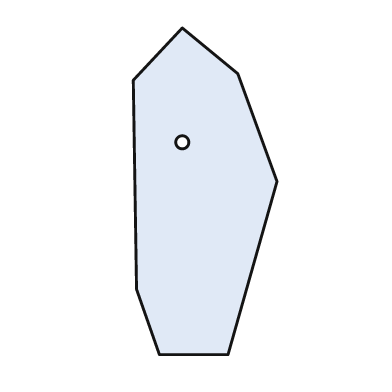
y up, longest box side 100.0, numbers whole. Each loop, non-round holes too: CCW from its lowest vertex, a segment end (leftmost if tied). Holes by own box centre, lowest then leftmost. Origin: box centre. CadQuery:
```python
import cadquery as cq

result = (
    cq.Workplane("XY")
    .moveTo(-14.0, -50.0)
    .lineTo(7.0, -50.0)
    .lineTo(22.0, 3.0)
    .lineTo(10.0, 36.0)
    .lineTo(-7.0, 50.0)
    .lineTo(-22.0, 34.0)
    .lineTo(-21.0, -30.0)
    .close()
    .moveTo(-7.0, 15.0)
    .circle(2.0)
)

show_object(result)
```